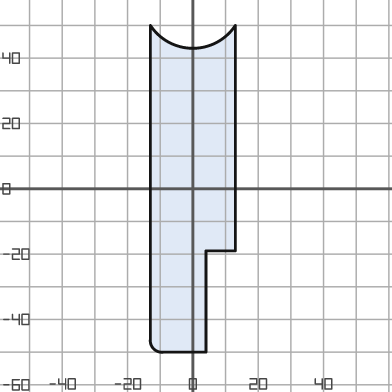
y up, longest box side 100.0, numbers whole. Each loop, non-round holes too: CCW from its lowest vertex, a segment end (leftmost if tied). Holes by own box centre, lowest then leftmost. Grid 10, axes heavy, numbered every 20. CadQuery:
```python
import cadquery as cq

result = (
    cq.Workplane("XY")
    .moveTo(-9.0, -50.0)
    .lineTo(4.0, -50.0)
    .lineTo(4.0, -19.0)
    .lineTo(13.0, -19.0)
    .lineTo(13.0, 50.0)
    .threePointArc((0.0, 43.0), (-13.0, 50.0))
    .lineTo(-13.0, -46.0)
    .threePointArc((-12.0, -49.0), (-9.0, -50.0))
    .close()
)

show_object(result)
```